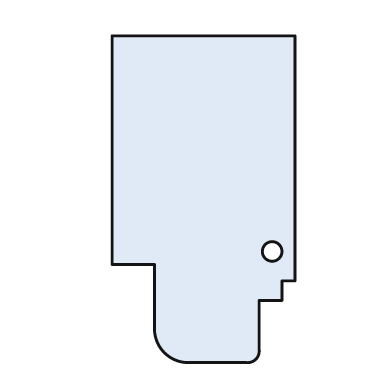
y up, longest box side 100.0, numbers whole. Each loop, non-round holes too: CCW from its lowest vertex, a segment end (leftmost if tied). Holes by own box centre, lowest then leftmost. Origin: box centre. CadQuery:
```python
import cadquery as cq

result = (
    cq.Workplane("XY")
    .moveTo(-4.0, -50.0)
    .lineTo(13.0, -50.0)
    .threePointArc((16.0, -49.0), (17.0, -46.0))
    .lineTo(17.0, -31.0)
    .lineTo(24.0, -31.0)
    .lineTo(24.0, -25.0)
    .lineTo(28.0, -25.0)
    .lineTo(28.0, 50.0)
    .lineTo(-28.0, 50.0)
    .lineTo(-28.0, -20.0)
    .lineTo(-15.0, -20.0)
    .lineTo(-15.0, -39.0)
    .threePointArc((-12.0, -47.0), (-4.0, -50.0))
    .close()
    .moveTo(21.0, -16.0)
    .circle(3.0)
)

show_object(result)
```